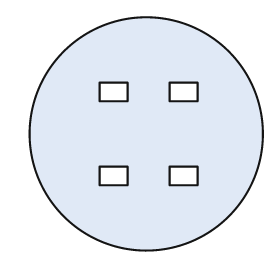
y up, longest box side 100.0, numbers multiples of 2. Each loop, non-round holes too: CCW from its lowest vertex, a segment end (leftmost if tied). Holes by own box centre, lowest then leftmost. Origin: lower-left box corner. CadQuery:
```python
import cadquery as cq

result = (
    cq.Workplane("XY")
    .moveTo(50.0, 50.0)
    .circle(50.0)
    .moveTo(30.0, 28.0)
    .lineTo(42.0, 28.0)
    .lineTo(42.0, 36.0)
    .lineTo(30.0, 36.0)
    .close()
    .moveTo(60.0, 28.0)
    .lineTo(72.0, 28.0)
    .lineTo(72.0, 36.0)
    .lineTo(60.0, 36.0)
    .close()
    .moveTo(30.0, 64.0)
    .lineTo(42.0, 64.0)
    .lineTo(42.0, 72.0)
    .lineTo(30.0, 72.0)
    .close()
    .moveTo(60.0, 64.0)
    .lineTo(72.0, 64.0)
    .lineTo(72.0, 72.0)
    .lineTo(60.0, 72.0)
    .close()
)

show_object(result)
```